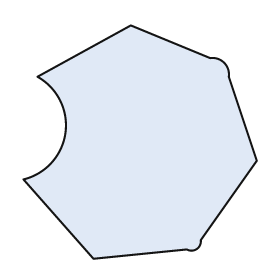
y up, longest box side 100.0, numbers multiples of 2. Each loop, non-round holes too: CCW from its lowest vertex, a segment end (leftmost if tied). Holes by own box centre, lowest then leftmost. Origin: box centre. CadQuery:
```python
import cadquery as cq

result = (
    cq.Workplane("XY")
    .moveTo(-20.0, -50.0)
    .lineTo(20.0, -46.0)
    .threePointArc((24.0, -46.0), (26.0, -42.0))
    .lineTo(50.0, -8.0)
    .lineTo(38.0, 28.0)
    .threePointArc((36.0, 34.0), (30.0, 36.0))
    .lineTo(-4.0, 50.0)
    .lineTo(-44.0, 28.0)
    .threePointArc((-32.0, 4.0), (-50.0, -16.0))
    .close()
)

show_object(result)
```